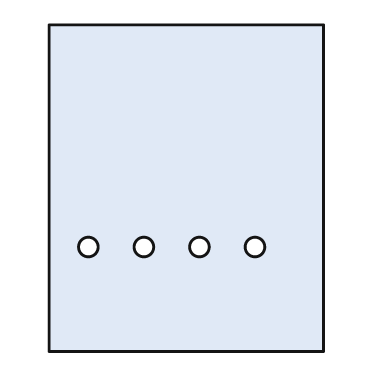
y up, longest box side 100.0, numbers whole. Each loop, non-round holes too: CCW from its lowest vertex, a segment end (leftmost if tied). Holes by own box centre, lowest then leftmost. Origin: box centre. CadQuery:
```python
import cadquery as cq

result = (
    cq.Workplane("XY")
    .moveTo(-42.0, -50.0)
    .lineTo(42.0, -50.0)
    .lineTo(42.0, 50.0)
    .lineTo(-42.0, 50.0)
    .close()
    .moveTo(-30.0, -18.0)
    .circle(3.0)
    .moveTo(-13.0, -18.0)
    .circle(3.0)
    .moveTo(4.0, -18.0)
    .circle(3.0)
    .moveTo(21.0, -18.0)
    .circle(3.0)
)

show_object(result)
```